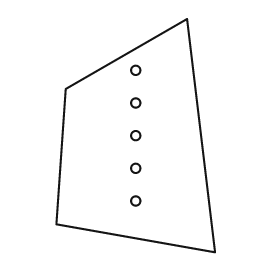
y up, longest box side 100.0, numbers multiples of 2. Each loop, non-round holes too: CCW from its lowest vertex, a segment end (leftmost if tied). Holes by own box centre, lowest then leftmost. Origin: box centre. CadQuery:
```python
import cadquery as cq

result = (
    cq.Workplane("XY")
    .moveTo(34.0, -50.0)
    .lineTo(22.0, 50.0)
    .lineTo(-30.0, 20.0)
    .lineTo(-34.0, -38.0)
    .close()
    .moveTo(0.0, -28.0)
    .circle(2.0)
    .moveTo(0.0, -14.0)
    .circle(2.0)
    .moveTo(0.0, 0.0)
    .circle(2.0)
    .moveTo(0.0, 14.0)
    .circle(2.0)
    .moveTo(0.0, 28.0)
    .circle(2.0)
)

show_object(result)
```